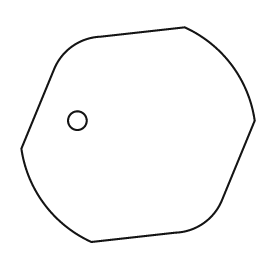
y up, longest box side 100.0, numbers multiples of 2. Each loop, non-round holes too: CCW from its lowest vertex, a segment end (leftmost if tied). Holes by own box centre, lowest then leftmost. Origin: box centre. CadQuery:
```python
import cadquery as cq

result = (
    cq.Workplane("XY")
    .moveTo(-20.0, -46.0)
    .lineTo(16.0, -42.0)
    .threePointArc((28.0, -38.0), (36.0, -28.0))
    .lineTo(50.0, 6.0)
    .threePointArc((40.0, 30.0), (20.0, 46.0))
    .lineTo(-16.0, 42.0)
    .threePointArc((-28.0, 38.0), (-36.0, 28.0))
    .lineTo(-50.0, -6.0)
    .threePointArc((-40.0, -30.0), (-20.0, -46.0))
    .close()
    .moveTo(-26.0, 6.0)
    .circle(4.0)
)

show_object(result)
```